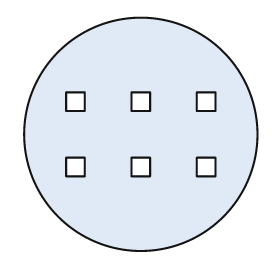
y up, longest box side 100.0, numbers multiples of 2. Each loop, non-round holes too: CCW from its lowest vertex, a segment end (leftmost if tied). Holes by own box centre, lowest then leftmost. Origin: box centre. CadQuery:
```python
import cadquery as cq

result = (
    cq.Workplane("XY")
    .moveTo(0.0, 0.0)
    .circle(50.0)
    .moveTo(-32.0, -18.0)
    .lineTo(-24.0, -18.0)
    .lineTo(-24.0, -10.0)
    .lineTo(-32.0, -10.0)
    .close()
    .moveTo(-4.0, -18.0)
    .lineTo(4.0, -18.0)
    .lineTo(4.0, -10.0)
    .lineTo(-4.0, -10.0)
    .close()
    .moveTo(24.0, -18.0)
    .lineTo(32.0, -18.0)
    .lineTo(32.0, -10.0)
    .lineTo(24.0, -10.0)
    .close()
    .moveTo(-32.0, 10.0)
    .lineTo(-24.0, 10.0)
    .lineTo(-24.0, 18.0)
    .lineTo(-32.0, 18.0)
    .close()
    .moveTo(-4.0, 10.0)
    .lineTo(4.0, 10.0)
    .lineTo(4.0, 18.0)
    .lineTo(-4.0, 18.0)
    .close()
    .moveTo(24.0, 10.0)
    .lineTo(32.0, 10.0)
    .lineTo(32.0, 18.0)
    .lineTo(24.0, 18.0)
    .close()
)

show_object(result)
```